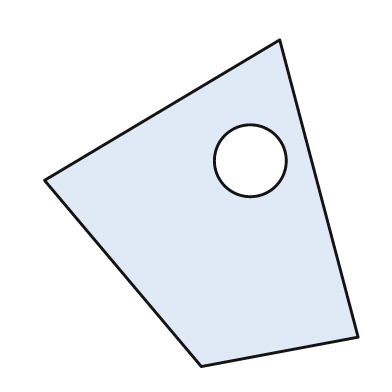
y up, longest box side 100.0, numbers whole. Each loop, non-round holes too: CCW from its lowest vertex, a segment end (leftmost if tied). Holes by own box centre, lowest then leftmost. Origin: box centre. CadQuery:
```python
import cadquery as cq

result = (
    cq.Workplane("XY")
    .moveTo(0.0, -50.0)
    .lineTo(48.0, -41.0)
    .lineTo(24.0, 50.0)
    .lineTo(-48.0, 7.0)
    .close()
    .moveTo(15.0, 13.0)
    .circle(11.0)
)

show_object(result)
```